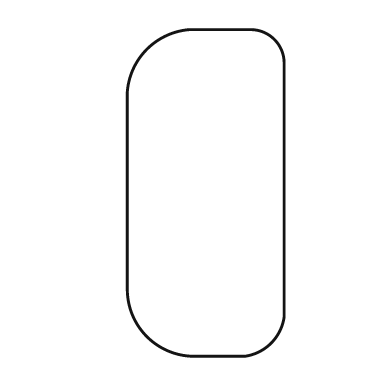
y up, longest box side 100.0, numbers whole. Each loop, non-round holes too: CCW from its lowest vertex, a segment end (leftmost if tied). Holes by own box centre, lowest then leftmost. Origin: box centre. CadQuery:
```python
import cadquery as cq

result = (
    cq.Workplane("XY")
    .moveTo(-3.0, -50.0)
    .lineTo(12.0, -50.0)
    .threePointArc((20.0, -46.0), (24.0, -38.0))
    .lineTo(24.0, 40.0)
    .threePointArc((21.0, 47.0), (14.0, 50.0))
    .lineTo(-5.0, 50.0)
    .threePointArc((-18.0, 44.0), (-24.0, 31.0))
    .lineTo(-24.0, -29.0)
    .threePointArc((-18.0, -44.0), (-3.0, -50.0))
    .close()
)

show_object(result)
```